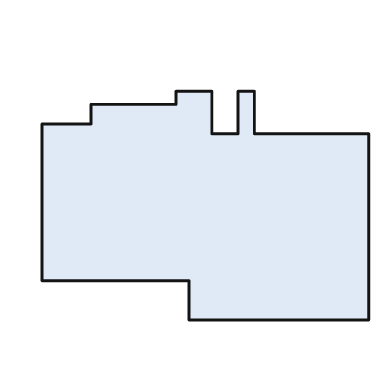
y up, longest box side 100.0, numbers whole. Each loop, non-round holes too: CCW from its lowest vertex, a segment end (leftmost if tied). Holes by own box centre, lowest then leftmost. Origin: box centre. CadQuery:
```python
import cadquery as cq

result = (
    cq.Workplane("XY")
    .moveTo(-5.0, -35.0)
    .lineTo(50.0, -35.0)
    .lineTo(50.0, 22.0)
    .lineTo(15.0, 22.0)
    .lineTo(15.0, 35.0)
    .lineTo(10.0, 35.0)
    .lineTo(10.0, 22.0)
    .lineTo(2.0, 22.0)
    .lineTo(2.0, 35.0)
    .lineTo(-9.0, 35.0)
    .lineTo(-9.0, 31.0)
    .lineTo(-35.0, 31.0)
    .lineTo(-35.0, 25.0)
    .lineTo(-50.0, 25.0)
    .lineTo(-50.0, -23.0)
    .lineTo(-5.0, -23.0)
    .close()
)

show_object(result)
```